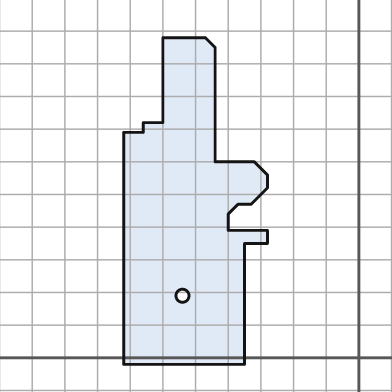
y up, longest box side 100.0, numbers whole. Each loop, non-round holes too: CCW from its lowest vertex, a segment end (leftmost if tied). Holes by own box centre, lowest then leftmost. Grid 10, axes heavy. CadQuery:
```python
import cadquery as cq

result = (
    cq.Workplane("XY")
    .moveTo(-72.0, -2.0)
    .lineTo(-35.0, -2.0)
    .lineTo(-35.0, 35.0)
    .lineTo(-28.0, 35.0)
    .lineTo(-28.0, 39.0)
    .lineTo(-40.0, 39.0)
    .lineTo(-40.0, 44.0)
    .lineTo(-37.0, 47.0)
    .lineTo(-33.0, 47.0)
    .lineTo(-28.0, 52.0)
    .lineTo(-28.0, 56.0)
    .lineTo(-32.0, 60.0)
    .lineTo(-44.0, 60.0)
    .lineTo(-44.0, 95.0)
    .lineTo(-47.0, 98.0)
    .lineTo(-60.0, 98.0)
    .lineTo(-60.0, 72.0)
    .lineTo(-66.0, 72.0)
    .lineTo(-66.0, 69.0)
    .lineTo(-72.0, 69.0)
    .close()
    .moveTo(-54.0, 19.0)
    .circle(2.0)
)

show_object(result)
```